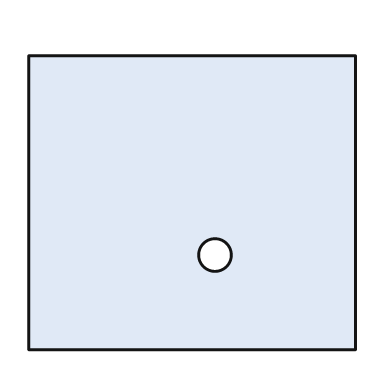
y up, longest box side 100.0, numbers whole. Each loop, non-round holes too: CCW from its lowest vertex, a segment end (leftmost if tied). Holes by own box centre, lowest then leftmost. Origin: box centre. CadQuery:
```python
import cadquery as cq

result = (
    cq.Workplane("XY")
    .moveTo(-50.0, -45.0)
    .lineTo(50.0, -45.0)
    .lineTo(50.0, 45.0)
    .lineTo(-50.0, 45.0)
    .close()
    .moveTo(7.0, -16.0)
    .circle(5.0)
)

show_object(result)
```